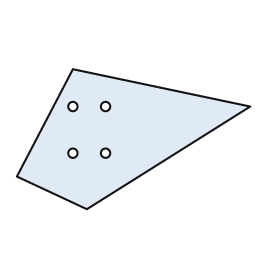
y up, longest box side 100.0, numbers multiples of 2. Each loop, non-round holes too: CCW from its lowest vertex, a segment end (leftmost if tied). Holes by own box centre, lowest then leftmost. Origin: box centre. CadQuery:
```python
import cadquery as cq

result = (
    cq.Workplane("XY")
    .moveTo(-20.0, -30.0)
    .lineTo(50.0, 14.0)
    .lineTo(-26.0, 30.0)
    .lineTo(-50.0, -16.0)
    .close()
    .moveTo(-26.0, -6.0)
    .circle(2.0)
    .moveTo(-12.0, -6.0)
    .circle(2.0)
    .moveTo(-26.0, 14.0)
    .circle(2.0)
    .moveTo(-12.0, 14.0)
    .circle(2.0)
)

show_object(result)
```